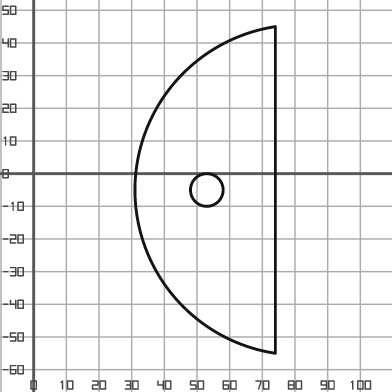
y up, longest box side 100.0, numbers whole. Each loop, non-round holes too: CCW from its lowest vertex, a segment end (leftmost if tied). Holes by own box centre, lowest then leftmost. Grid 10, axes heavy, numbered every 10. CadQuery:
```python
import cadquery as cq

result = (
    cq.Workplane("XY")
    .moveTo(74.0, -55.0)
    .lineTo(74.0, 45.0)
    .threePointArc((31.0, -5.0), (74.0, -55.0))
    .close()
    .moveTo(53.0, -5.0)
    .circle(5.0)
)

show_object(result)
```